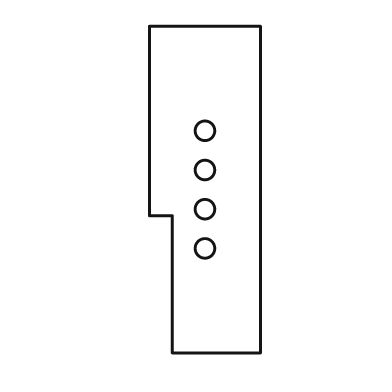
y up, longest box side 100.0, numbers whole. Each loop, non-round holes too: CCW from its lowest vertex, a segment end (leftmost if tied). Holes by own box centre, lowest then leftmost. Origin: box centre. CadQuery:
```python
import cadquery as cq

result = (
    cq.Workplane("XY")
    .moveTo(-10.0, -50.0)
    .lineTo(17.0, -50.0)
    .lineTo(17.0, 50.0)
    .lineTo(-17.0, 50.0)
    .lineTo(-17.0, -8.0)
    .lineTo(-10.0, -8.0)
    .close()
    .moveTo(0.0, -18.0)
    .circle(3.0)
    .moveTo(0.0, -6.0)
    .circle(3.0)
    .moveTo(0.0, 6.0)
    .circle(3.0)
    .moveTo(0.0, 18.0)
    .circle(3.0)
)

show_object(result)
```